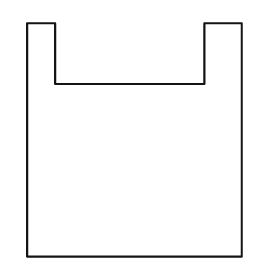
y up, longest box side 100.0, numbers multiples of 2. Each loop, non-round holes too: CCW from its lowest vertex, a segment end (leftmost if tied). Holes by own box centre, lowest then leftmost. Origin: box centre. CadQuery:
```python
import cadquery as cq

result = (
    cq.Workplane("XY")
    .moveTo(-46.0, -50.0)
    .lineTo(46.0, -50.0)
    .lineTo(46.0, 50.0)
    .lineTo(30.0, 50.0)
    .lineTo(30.0, 24.0)
    .lineTo(-34.0, 24.0)
    .lineTo(-34.0, 50.0)
    .lineTo(-46.0, 50.0)
    .close()
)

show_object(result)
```